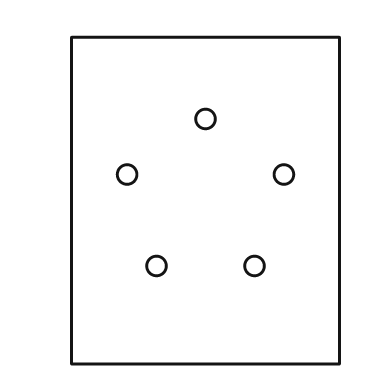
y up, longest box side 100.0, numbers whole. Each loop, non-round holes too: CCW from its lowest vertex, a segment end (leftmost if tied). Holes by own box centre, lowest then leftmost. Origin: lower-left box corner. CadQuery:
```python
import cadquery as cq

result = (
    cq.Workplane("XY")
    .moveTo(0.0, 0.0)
    .lineTo(82.0, 0.0)
    .lineTo(82.0, 100.0)
    .lineTo(0.0, 100.0)
    .close()
    .moveTo(26.0, 30.0)
    .circle(3.0)
    .moveTo(56.0, 30.0)
    .circle(3.0)
    .moveTo(17.0, 58.0)
    .circle(3.0)
    .moveTo(65.0, 58.0)
    .circle(3.0)
    .moveTo(41.0, 75.0)
    .circle(3.0)
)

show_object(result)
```